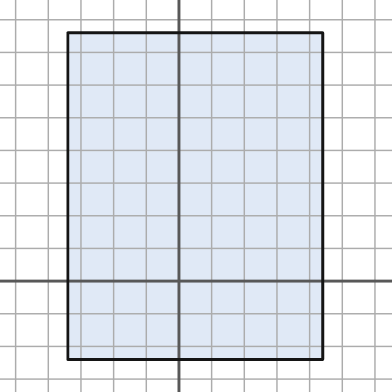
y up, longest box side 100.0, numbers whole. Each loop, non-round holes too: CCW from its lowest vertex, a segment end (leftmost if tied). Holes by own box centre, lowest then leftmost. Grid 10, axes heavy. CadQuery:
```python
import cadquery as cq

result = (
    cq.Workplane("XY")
    .moveTo(-34.0, -24.0)
    .lineTo(44.0, -24.0)
    .lineTo(44.0, 76.0)
    .lineTo(-34.0, 76.0)
    .close()
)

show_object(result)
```